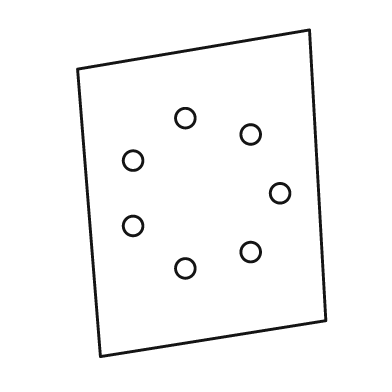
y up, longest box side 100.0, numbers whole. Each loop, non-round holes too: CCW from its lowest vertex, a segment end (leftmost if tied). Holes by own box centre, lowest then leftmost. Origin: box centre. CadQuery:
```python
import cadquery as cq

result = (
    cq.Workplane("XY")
    .moveTo(-31.0, -50.0)
    .lineTo(38.0, -39.0)
    .lineTo(33.0, 50.0)
    .lineTo(-38.0, 38.0)
    .close()
    .moveTo(-5.0, -23.0)
    .circle(3.0)
    .moveTo(15.0, -18.0)
    .circle(3.0)
    .moveTo(-21.0, -10.0)
    .circle(3.0)
    .moveTo(24.0, 0.0)
    .circle(3.0)
    .moveTo(-21.0, 10.0)
    .circle(3.0)
    .moveTo(15.0, 18.0)
    .circle(3.0)
    .moveTo(-5.0, 23.0)
    .circle(3.0)
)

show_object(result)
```